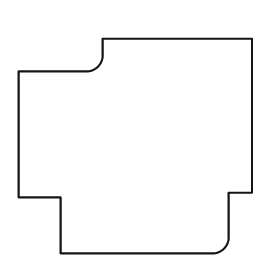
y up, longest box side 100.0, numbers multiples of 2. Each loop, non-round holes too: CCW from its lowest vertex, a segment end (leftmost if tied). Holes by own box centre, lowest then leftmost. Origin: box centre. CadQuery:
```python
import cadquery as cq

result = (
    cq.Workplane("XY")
    .moveTo(-32.0, -46.0)
    .lineTo(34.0, -46.0)
    .threePointArc((38.0, -44.0), (40.0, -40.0))
    .lineTo(40.0, -20.0)
    .lineTo(50.0, -20.0)
    .lineTo(50.0, 46.0)
    .lineTo(-14.0, 46.0)
    .lineTo(-14.0, 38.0)
    .threePointArc((-16.0, 34.0), (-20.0, 32.0))
    .lineTo(-50.0, 32.0)
    .lineTo(-50.0, -22.0)
    .lineTo(-32.0, -22.0)
    .close()
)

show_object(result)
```